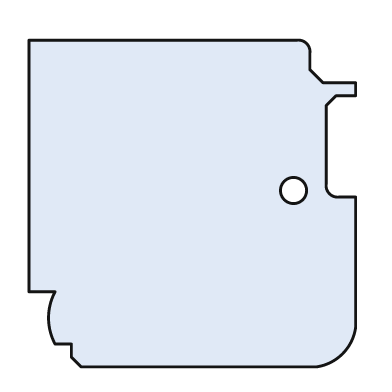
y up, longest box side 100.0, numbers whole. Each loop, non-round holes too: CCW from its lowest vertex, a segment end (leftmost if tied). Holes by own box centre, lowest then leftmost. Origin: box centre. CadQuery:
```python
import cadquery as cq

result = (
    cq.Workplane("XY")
    .moveTo(-34.0, -50.0)
    .lineTo(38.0, -50.0)
    .threePointArc((46.0, -46.0), (50.0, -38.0))
    .lineTo(50.0, 2.0)
    .lineTo(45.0, 2.0)
    .threePointArc((42.0, 3.0), (41.0, 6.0))
    .lineTo(41.0, 30.0)
    .lineTo(44.0, 33.0)
    .lineTo(50.0, 33.0)
    .lineTo(50.0, 37.0)
    .lineTo(40.0, 37.0)
    .lineTo(36.0, 41.0)
    .lineTo(36.0, 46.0)
    .threePointArc((35.0, 49.0), (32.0, 50.0))
    .lineTo(-50.0, 50.0)
    .lineTo(-50.0, -27.0)
    .lineTo(-42.0, -27.0)
    .threePointArc((-44.0, -35.0), (-42.0, -43.0))
    .lineTo(-37.0, -43.0)
    .lineTo(-37.0, -47.0)
    .close()
    .moveTo(31.0, 4.0)
    .circle(4.0)
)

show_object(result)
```